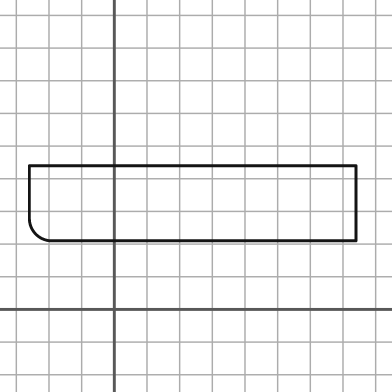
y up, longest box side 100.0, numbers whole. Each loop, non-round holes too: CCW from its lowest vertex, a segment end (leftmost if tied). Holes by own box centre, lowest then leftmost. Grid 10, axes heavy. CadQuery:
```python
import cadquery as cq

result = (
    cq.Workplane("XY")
    .moveTo(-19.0, 21.0)
    .lineTo(74.0, 21.0)
    .lineTo(74.0, 44.0)
    .lineTo(-26.0, 44.0)
    .lineTo(-26.0, 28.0)
    .threePointArc((-24.0, 23.0), (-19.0, 21.0))
    .close()
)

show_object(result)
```